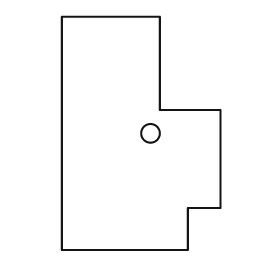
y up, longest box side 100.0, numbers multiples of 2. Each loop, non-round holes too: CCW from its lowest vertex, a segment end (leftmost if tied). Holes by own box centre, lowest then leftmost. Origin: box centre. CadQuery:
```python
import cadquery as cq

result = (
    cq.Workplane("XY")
    .moveTo(-34.0, -50.0)
    .lineTo(20.0, -50.0)
    .lineTo(20.0, -32.0)
    .lineTo(34.0, -32.0)
    .lineTo(34.0, 10.0)
    .lineTo(8.0, 10.0)
    .lineTo(8.0, 50.0)
    .lineTo(-34.0, 50.0)
    .close()
    .moveTo(4.0, 0.0)
    .circle(4.0)
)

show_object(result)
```